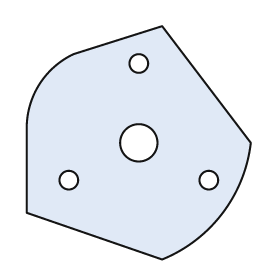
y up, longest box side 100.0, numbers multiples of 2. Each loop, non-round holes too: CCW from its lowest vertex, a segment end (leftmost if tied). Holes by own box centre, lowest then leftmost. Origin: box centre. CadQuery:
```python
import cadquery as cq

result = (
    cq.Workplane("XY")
    .moveTo(10.0, -50.0)
    .threePointArc((36.0, -30.0), (48.0, 0.0))
    .lineTo(10.0, 50.0)
    .lineTo(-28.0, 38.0)
    .threePointArc((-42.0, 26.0), (-48.0, 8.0))
    .lineTo(-48.0, -30.0)
    .close()
    .moveTo(-30.0, -16.0)
    .circle(4.0)
    .moveTo(30.0, -16.0)
    .circle(4.0)
    .moveTo(0.0, 0.0)
    .circle(8.0)
    .moveTo(0.0, 34.0)
    .circle(4.0)
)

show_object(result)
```